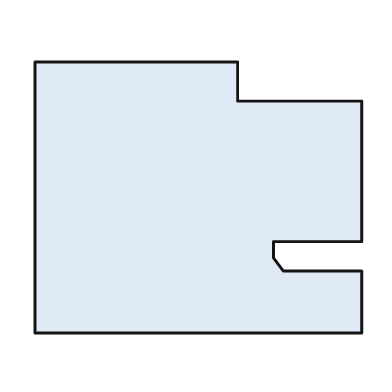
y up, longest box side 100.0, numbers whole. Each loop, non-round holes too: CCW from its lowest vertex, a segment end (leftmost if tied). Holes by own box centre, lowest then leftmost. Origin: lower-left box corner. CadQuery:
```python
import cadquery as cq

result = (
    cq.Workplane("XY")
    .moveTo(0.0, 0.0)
    .lineTo(100.0, 0.0)
    .lineTo(100.0, 19.0)
    .lineTo(76.0, 19.0)
    .lineTo(73.0, 23.0)
    .lineTo(73.0, 28.0)
    .lineTo(100.0, 28.0)
    .lineTo(100.0, 71.0)
    .lineTo(62.0, 71.0)
    .lineTo(62.0, 83.0)
    .lineTo(0.0, 83.0)
    .close()
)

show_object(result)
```